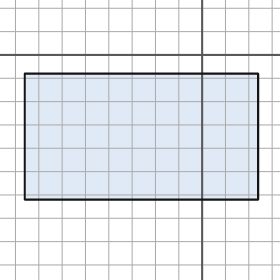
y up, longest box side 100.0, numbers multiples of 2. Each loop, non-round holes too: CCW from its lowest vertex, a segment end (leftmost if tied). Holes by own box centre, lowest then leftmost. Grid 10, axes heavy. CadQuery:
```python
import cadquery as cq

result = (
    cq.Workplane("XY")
    .moveTo(-76.0, -62.0)
    .lineTo(24.0, -62.0)
    .lineTo(24.0, -8.0)
    .lineTo(-76.0, -8.0)
    .close()
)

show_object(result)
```